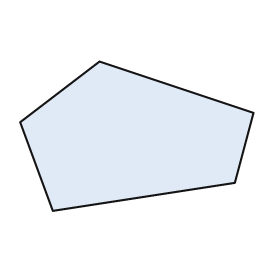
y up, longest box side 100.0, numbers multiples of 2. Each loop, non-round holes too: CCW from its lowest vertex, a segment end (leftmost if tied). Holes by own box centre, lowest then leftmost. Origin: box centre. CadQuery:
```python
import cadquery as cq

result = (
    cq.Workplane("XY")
    .moveTo(-36.0, -32.0)
    .lineTo(42.0, -20.0)
    .lineTo(50.0, 10.0)
    .lineTo(-16.0, 32.0)
    .lineTo(-50.0, 6.0)
    .close()
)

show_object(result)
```